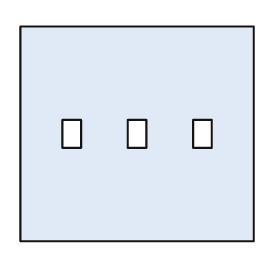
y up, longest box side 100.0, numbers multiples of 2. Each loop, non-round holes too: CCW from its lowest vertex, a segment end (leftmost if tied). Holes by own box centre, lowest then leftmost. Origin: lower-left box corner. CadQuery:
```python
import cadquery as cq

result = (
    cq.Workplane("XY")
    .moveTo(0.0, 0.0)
    .lineTo(100.0, 0.0)
    .lineTo(100.0, 92.0)
    .lineTo(0.0, 92.0)
    .close()
    .moveTo(18.0, 40.0)
    .lineTo(26.0, 40.0)
    .lineTo(26.0, 52.0)
    .lineTo(18.0, 52.0)
    .close()
    .moveTo(46.0, 40.0)
    .lineTo(54.0, 40.0)
    .lineTo(54.0, 52.0)
    .lineTo(46.0, 52.0)
    .close()
    .moveTo(74.0, 40.0)
    .lineTo(82.0, 40.0)
    .lineTo(82.0, 52.0)
    .lineTo(74.0, 52.0)
    .close()
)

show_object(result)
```